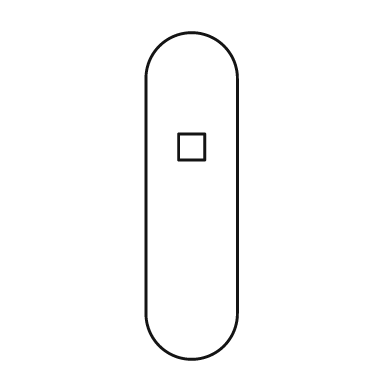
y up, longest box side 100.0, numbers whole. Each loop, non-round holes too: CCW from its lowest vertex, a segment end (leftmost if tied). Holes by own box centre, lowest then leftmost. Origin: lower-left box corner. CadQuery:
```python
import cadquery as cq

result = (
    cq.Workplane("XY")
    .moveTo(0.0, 14.0)
    .threePointArc((14.0, 0.0), (28.0, 14.0))
    .lineTo(28.0, 86.0)
    .threePointArc((14.0, 100.0), (0.0, 86.0))
    .close()
    .moveTo(10.0, 61.0)
    .lineTo(18.0, 61.0)
    .lineTo(18.0, 69.0)
    .lineTo(10.0, 69.0)
    .close()
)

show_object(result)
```